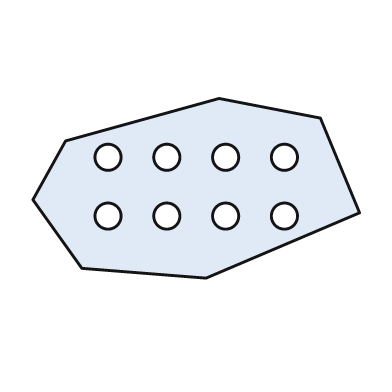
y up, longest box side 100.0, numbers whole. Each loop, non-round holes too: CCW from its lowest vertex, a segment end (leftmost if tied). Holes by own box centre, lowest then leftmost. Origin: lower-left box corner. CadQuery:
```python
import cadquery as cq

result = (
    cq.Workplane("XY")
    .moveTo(53.0, 0.0)
    .lineTo(100.0, 20.0)
    .lineTo(88.0, 49.0)
    .lineTo(57.0, 55.0)
    .lineTo(10.0, 42.0)
    .lineTo(0.0, 24.0)
    .lineTo(15.0, 3.0)
    .close()
    .moveTo(23.0, 19.0)
    .circle(4.0)
    .moveTo(41.0, 19.0)
    .circle(4.0)
    .moveTo(59.0, 19.0)
    .circle(4.0)
    .moveTo(77.0, 19.0)
    .circle(4.0)
    .moveTo(23.0, 37.0)
    .circle(4.0)
    .moveTo(41.0, 37.0)
    .circle(4.0)
    .moveTo(59.0, 37.0)
    .circle(4.0)
    .moveTo(77.0, 37.0)
    .circle(4.0)
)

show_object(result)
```